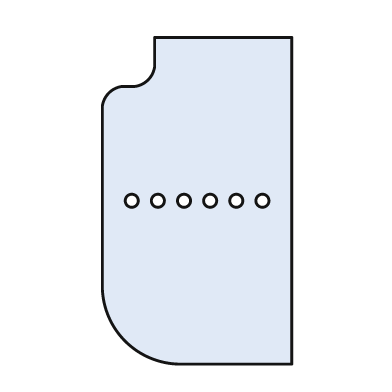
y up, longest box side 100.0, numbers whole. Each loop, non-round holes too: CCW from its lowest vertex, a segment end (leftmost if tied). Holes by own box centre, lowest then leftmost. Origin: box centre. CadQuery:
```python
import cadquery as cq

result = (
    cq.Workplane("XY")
    .moveTo(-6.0, -50.0)
    .lineTo(29.0, -50.0)
    .lineTo(29.0, 50.0)
    .lineTo(-13.0, 50.0)
    .lineTo(-13.0, 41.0)
    .threePointArc((-15.0, 37.0), (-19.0, 35.0))
    .lineTo(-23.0, 35.0)
    .threePointArc((-27.0, 33.0), (-29.0, 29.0))
    .lineTo(-29.0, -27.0)
    .threePointArc((-22.0, -43.0), (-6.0, -50.0))
    .close()
    .moveTo(-20.0, 0.0)
    .circle(2.0)
    .moveTo(-12.0, 0.0)
    .circle(2.0)
    .moveTo(-4.0, 0.0)
    .circle(2.0)
    .moveTo(4.0, 0.0)
    .circle(2.0)
    .moveTo(12.0, 0.0)
    .circle(2.0)
    .moveTo(20.0, 0.0)
    .circle(2.0)
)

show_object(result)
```